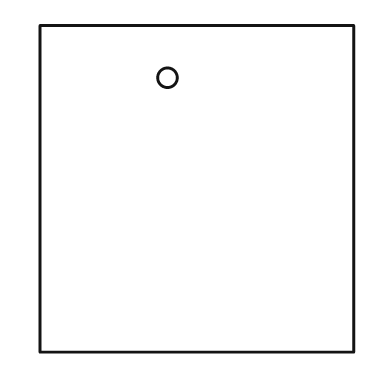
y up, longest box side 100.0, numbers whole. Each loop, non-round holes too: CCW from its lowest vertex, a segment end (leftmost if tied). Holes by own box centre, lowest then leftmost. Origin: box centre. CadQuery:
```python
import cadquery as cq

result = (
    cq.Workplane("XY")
    .moveTo(-48.0, -50.0)
    .lineTo(48.0, -50.0)
    .lineTo(48.0, 50.0)
    .lineTo(-48.0, 50.0)
    .close()
    .moveTo(-9.0, 34.0)
    .circle(3.0)
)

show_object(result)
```